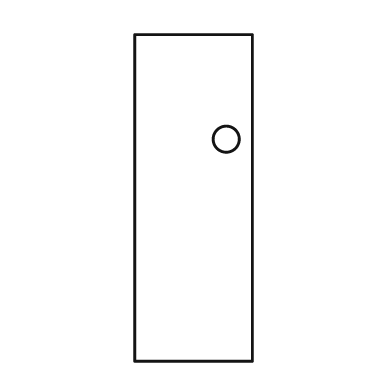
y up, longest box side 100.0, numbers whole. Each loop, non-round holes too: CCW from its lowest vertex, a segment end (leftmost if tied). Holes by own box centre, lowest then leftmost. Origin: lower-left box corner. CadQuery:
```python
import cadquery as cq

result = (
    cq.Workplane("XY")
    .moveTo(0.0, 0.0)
    .lineTo(36.0, 0.0)
    .lineTo(36.0, 100.0)
    .lineTo(0.0, 100.0)
    .close()
    .moveTo(28.0, 68.0)
    .circle(4.0)
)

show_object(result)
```